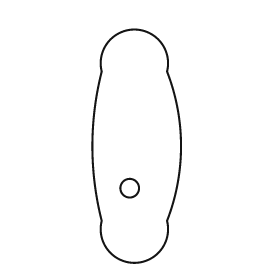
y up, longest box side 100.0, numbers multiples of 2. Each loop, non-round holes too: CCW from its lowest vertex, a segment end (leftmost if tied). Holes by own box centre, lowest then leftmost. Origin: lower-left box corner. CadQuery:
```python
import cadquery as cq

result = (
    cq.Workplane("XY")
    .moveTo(4.0, 18.0)
    .threePointArc((18.0, 0.0), (32.0, 18.0))
    .threePointArc((38.0, 50.0), (32.0, 82.0))
    .threePointArc((18.0, 100.0), (4.0, 82.0))
    .threePointArc((0.0, 50.0), (4.0, 18.0))
    .close()
    .moveTo(16.0, 32.0)
    .circle(4.0)
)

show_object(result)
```